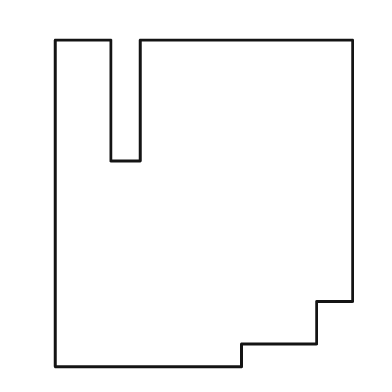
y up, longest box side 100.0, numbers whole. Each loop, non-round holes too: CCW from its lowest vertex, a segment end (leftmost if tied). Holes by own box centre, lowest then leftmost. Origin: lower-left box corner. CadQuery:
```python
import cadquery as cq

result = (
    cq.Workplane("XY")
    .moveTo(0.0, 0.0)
    .lineTo(57.0, 0.0)
    .lineTo(57.0, 7.0)
    .lineTo(80.0, 7.0)
    .lineTo(80.0, 20.0)
    .lineTo(91.0, 20.0)
    .lineTo(91.0, 100.0)
    .lineTo(26.0, 100.0)
    .lineTo(26.0, 63.0)
    .lineTo(17.0, 63.0)
    .lineTo(17.0, 100.0)
    .lineTo(0.0, 100.0)
    .close()
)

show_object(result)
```